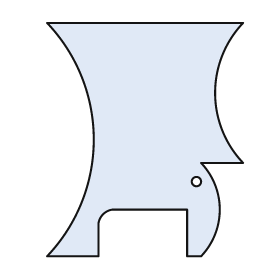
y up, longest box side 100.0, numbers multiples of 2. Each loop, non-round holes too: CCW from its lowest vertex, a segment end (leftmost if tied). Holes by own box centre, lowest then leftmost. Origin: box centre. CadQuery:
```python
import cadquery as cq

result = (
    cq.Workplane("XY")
    .moveTo(-42.0, -50.0)
    .lineTo(-20.0, -50.0)
    .lineTo(-20.0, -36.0)
    .threePointArc((-18.0, -32.0), (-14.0, -30.0))
    .lineTo(18.0, -30.0)
    .lineTo(18.0, -50.0)
    .lineTo(24.0, -50.0)
    .threePointArc((32.0, -30.0), (24.0, -10.0))
    .lineTo(42.0, -10.0)
    .threePointArc((30.0, 20.0), (42.0, 50.0))
    .lineTo(-42.0, 50.0)
    .threePointArc((-22.0, 0.0), (-42.0, -50.0))
    .close()
    .moveTo(22.0, -18.0)
    .circle(2.0)
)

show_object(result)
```